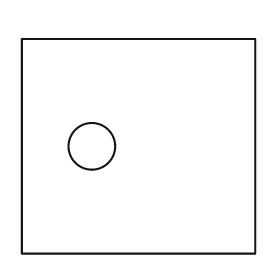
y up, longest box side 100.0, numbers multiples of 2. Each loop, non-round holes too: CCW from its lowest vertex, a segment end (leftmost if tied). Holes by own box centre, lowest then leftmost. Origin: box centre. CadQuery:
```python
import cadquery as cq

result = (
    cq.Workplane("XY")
    .moveTo(-50.0, -46.0)
    .lineTo(50.0, -46.0)
    .lineTo(50.0, 46.0)
    .lineTo(-50.0, 46.0)
    .close()
    .moveTo(-20.0, 0.0)
    .circle(10.0)
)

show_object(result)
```